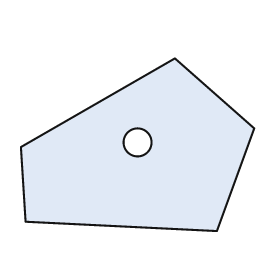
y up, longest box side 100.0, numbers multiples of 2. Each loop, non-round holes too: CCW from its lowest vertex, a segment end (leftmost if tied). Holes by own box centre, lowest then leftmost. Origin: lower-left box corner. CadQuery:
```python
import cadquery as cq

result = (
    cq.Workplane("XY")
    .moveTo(84.0, 0.0)
    .lineTo(100.0, 44.0)
    .lineTo(66.0, 74.0)
    .lineTo(0.0, 36.0)
    .lineTo(2.0, 4.0)
    .close()
    .moveTo(50.0, 38.0)
    .circle(6.0)
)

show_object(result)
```